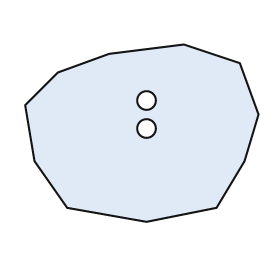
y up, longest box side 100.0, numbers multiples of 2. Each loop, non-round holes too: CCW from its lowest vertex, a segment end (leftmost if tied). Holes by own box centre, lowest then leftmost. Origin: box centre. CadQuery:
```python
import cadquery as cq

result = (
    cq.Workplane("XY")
    .moveTo(2.0, -38.0)
    .lineTo(32.0, -32.0)
    .lineTo(44.0, -12.0)
    .lineTo(50.0, 8.0)
    .lineTo(42.0, 30.0)
    .lineTo(18.0, 38.0)
    .lineTo(-14.0, 34.0)
    .lineTo(-36.0, 26.0)
    .lineTo(-50.0, 12.0)
    .lineTo(-46.0, -12.0)
    .lineTo(-32.0, -32.0)
    .close()
    .moveTo(2.0, 2.0)
    .circle(4.0)
    .moveTo(2.0, 14.0)
    .circle(4.0)
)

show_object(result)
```